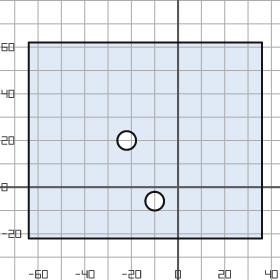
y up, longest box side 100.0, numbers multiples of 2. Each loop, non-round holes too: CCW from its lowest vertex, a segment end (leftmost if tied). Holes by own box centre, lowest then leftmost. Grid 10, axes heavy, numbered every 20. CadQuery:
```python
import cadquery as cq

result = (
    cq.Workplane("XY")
    .moveTo(-64.0, -22.0)
    .lineTo(36.0, -22.0)
    .lineTo(36.0, 62.0)
    .lineTo(-64.0, 62.0)
    .close()
    .moveTo(-10.0, -6.0)
    .circle(4.0)
    .moveTo(-22.0, 20.0)
    .circle(4.0)
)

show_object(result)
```